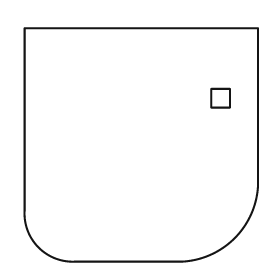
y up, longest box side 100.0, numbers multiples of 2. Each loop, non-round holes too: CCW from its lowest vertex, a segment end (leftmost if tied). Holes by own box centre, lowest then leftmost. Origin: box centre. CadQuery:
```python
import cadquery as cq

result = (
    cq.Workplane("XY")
    .moveTo(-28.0, -50.0)
    .lineTo(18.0, -50.0)
    .threePointArc((40.0, -40.0), (50.0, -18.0))
    .lineTo(50.0, 50.0)
    .lineTo(-50.0, 50.0)
    .lineTo(-50.0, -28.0)
    .threePointArc((-44.0, -44.0), (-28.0, -50.0))
    .close()
    .moveTo(30.0, 16.0)
    .lineTo(38.0, 16.0)
    .lineTo(38.0, 24.0)
    .lineTo(30.0, 24.0)
    .close()
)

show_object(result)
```